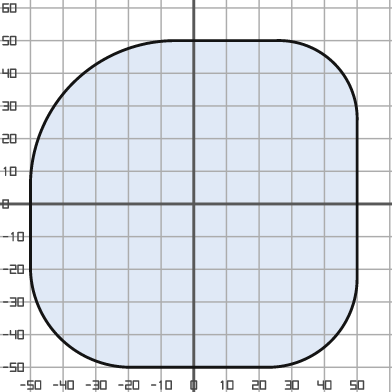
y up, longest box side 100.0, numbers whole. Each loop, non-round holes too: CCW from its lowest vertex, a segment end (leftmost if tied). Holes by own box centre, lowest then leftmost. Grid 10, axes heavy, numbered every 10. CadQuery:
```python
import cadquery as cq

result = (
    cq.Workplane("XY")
    .moveTo(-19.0, -50.0)
    .lineTo(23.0, -50.0)
    .threePointArc((42.0, -42.0), (50.0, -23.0))
    .lineTo(50.0, 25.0)
    .threePointArc((43.0, 43.0), (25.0, 50.0))
    .lineTo(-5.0, 50.0)
    .threePointArc((-37.0, 37.0), (-50.0, 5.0))
    .lineTo(-50.0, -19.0)
    .threePointArc((-41.0, -41.0), (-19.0, -50.0))
    .close()
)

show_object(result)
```